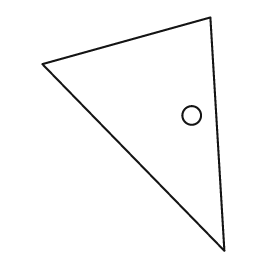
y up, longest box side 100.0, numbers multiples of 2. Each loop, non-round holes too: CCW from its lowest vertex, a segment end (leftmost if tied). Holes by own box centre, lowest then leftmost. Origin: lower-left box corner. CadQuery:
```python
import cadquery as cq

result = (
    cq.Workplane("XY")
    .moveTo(78.0, 0.0)
    .lineTo(72.0, 100.0)
    .lineTo(0.0, 80.0)
    .close()
    .moveTo(64.0, 58.0)
    .circle(4.0)
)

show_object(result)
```